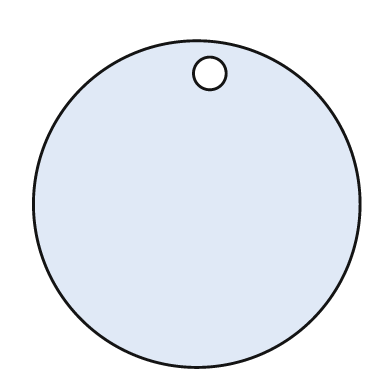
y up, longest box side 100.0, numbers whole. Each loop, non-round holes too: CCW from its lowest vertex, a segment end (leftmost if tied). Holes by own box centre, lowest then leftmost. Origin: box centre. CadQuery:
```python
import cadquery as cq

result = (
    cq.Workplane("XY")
    .moveTo(0.0, 0.0)
    .circle(50.0)
    .moveTo(4.0, 40.0)
    .circle(5.0)
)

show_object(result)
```